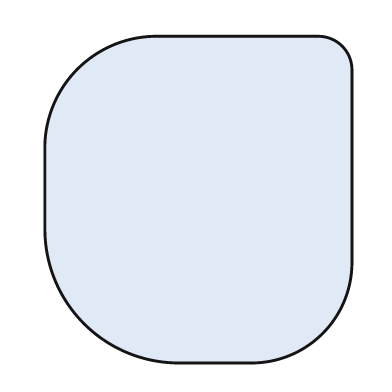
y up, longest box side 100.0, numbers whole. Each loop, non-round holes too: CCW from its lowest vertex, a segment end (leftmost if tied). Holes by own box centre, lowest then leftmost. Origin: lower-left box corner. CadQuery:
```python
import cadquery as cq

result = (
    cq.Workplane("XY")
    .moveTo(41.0, 0.0)
    .lineTo(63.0, 0.0)
    .threePointArc((85.0, 9.0), (94.0, 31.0))
    .lineTo(94.0, 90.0)
    .threePointArc((91.0, 97.0), (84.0, 100.0))
    .lineTo(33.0, 100.0)
    .threePointArc((10.0, 90.0), (0.0, 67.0))
    .lineTo(0.0, 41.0)
    .threePointArc((12.0, 12.0), (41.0, 0.0))
    .close()
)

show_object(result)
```